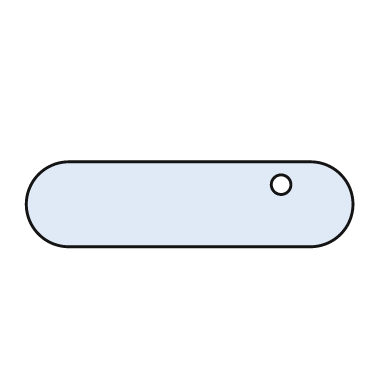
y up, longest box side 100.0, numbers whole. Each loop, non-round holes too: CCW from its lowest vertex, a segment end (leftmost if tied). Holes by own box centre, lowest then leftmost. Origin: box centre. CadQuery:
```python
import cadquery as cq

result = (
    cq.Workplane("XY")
    .moveTo(-37.0, -13.0)
    .lineTo(37.0, -13.0)
    .threePointArc((50.0, 0.0), (37.0, 13.0))
    .lineTo(-37.0, 13.0)
    .threePointArc((-50.0, 0.0), (-37.0, -13.0))
    .close()
    .moveTo(28.0, 6.0)
    .circle(3.0)
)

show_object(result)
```